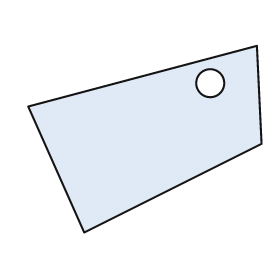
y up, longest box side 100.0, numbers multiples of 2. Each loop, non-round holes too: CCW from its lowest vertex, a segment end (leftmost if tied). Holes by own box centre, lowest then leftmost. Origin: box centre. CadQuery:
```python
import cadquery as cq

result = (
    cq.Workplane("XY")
    .moveTo(-26.0, -40.0)
    .lineTo(50.0, -2.0)
    .lineTo(48.0, 40.0)
    .lineTo(-50.0, 14.0)
    .close()
    .moveTo(28.0, 24.0)
    .circle(6.0)
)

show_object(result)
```